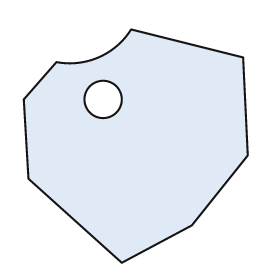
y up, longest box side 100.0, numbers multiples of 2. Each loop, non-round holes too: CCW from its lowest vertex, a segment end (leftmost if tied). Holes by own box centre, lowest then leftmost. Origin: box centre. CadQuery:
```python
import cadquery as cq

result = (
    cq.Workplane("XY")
    .moveTo(-6.0, -50.0)
    .lineTo(24.0, -34.0)
    .lineTo(48.0, -4.0)
    .lineTo(46.0, 38.0)
    .lineTo(-2.0, 50.0)
    .threePointArc((-16.0, 38.0), (-34.0, 36.0))
    .lineTo(-48.0, 20.0)
    .lineTo(-46.0, -14.0)
    .close()
    .moveTo(-14.0, 20.0)
    .circle(8.0)
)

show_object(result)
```